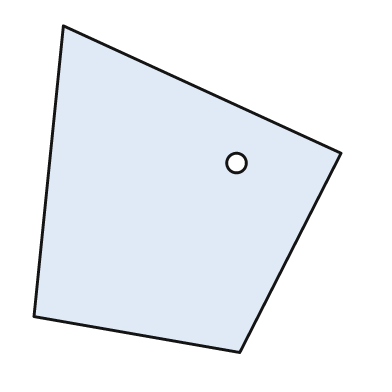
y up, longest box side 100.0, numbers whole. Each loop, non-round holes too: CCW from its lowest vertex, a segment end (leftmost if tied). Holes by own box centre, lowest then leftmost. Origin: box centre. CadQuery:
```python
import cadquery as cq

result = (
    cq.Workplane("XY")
    .moveTo(16.0, -50.0)
    .lineTo(47.0, 11.0)
    .lineTo(-38.0, 50.0)
    .lineTo(-47.0, -39.0)
    .close()
    .moveTo(15.0, 8.0)
    .circle(3.0)
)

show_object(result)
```